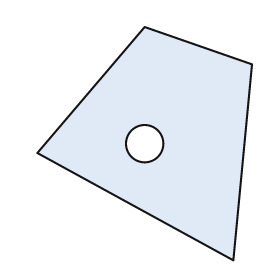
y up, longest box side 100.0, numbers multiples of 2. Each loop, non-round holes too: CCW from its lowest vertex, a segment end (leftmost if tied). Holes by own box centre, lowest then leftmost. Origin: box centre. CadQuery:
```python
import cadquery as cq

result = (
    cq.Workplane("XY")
    .moveTo(38.0, -50.0)
    .lineTo(46.0, 34.0)
    .lineTo(0.0, 50.0)
    .lineTo(-46.0, -4.0)
    .close()
    .moveTo(0.0, 0.0)
    .circle(8.0)
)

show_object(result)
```